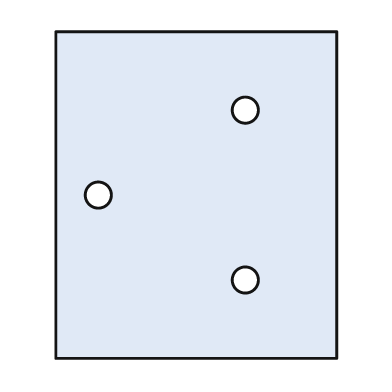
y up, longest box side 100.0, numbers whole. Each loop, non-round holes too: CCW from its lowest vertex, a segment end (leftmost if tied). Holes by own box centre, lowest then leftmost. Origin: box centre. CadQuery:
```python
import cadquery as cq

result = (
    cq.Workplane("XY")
    .moveTo(-43.0, -50.0)
    .lineTo(43.0, -50.0)
    .lineTo(43.0, 50.0)
    .lineTo(-43.0, 50.0)
    .close()
    .moveTo(15.0, -26.0)
    .circle(4.0)
    .moveTo(-30.0, 0.0)
    .circle(4.0)
    .moveTo(15.0, 26.0)
    .circle(4.0)
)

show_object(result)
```